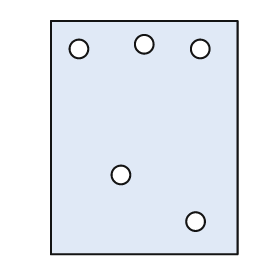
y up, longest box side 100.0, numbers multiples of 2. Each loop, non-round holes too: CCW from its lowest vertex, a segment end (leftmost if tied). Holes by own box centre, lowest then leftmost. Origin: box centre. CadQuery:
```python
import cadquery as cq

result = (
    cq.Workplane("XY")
    .moveTo(-40.0, -50.0)
    .lineTo(40.0, -50.0)
    .lineTo(40.0, 50.0)
    .lineTo(-40.0, 50.0)
    .close()
    .moveTo(22.0, -36.0)
    .circle(4.0)
    .moveTo(-10.0, -16.0)
    .circle(4.0)
    .moveTo(-28.0, 38.0)
    .circle(4.0)
    .moveTo(24.0, 38.0)
    .circle(4.0)
    .moveTo(0.0, 40.0)
    .circle(4.0)
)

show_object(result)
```